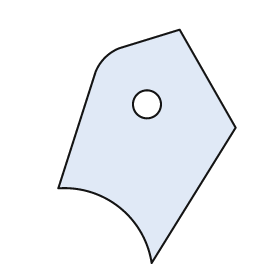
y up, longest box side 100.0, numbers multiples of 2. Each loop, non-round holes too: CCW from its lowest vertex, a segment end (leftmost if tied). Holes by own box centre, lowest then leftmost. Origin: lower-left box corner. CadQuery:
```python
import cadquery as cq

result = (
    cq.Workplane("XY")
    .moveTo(40.0, 0.0)
    .lineTo(76.0, 58.0)
    .lineTo(52.0, 100.0)
    .lineTo(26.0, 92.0)
    .threePointArc((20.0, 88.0), (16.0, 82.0))
    .lineTo(0.0, 32.0)
    .threePointArc((26.0, 24.0), (40.0, 0.0))
    .close()
    .moveTo(38.0, 68.0)
    .circle(6.0)
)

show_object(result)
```